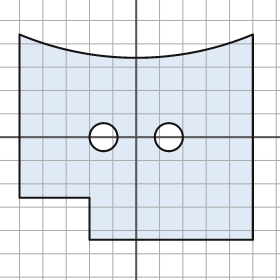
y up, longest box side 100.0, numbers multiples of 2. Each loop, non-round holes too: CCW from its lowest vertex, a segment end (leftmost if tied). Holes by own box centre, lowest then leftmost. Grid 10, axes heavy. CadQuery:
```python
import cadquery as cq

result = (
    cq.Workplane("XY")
    .moveTo(-20.0, -44.0)
    .lineTo(50.0, -44.0)
    .lineTo(50.0, 44.0)
    .threePointArc((0.0, 34.0), (-50.0, 44.0))
    .lineTo(-50.0, -26.0)
    .lineTo(-20.0, -26.0)
    .close()
    .moveTo(-14.0, 0.0)
    .circle(6.0)
    .moveTo(14.0, 0.0)
    .circle(6.0)
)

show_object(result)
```